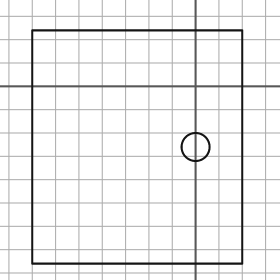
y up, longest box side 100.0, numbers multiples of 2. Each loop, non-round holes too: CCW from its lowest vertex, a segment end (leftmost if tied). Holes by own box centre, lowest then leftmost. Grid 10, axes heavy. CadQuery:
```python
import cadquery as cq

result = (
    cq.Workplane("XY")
    .moveTo(-70.0, -76.0)
    .lineTo(20.0, -76.0)
    .lineTo(20.0, 24.0)
    .lineTo(-70.0, 24.0)
    .close()
    .moveTo(0.0, -26.0)
    .circle(6.0)
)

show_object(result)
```